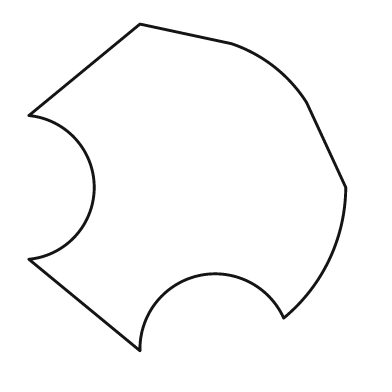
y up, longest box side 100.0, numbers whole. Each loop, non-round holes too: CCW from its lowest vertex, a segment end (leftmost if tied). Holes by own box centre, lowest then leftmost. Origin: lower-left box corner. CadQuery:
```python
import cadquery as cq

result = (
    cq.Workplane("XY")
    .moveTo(34.0, 0.0)
    .threePointArc((52.0, 23.0), (78.0, 10.0))
    .threePointArc((92.0, 28.0), (97.0, 50.0))
    .lineTo(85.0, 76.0)
    .threePointArc((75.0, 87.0), (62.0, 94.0))
    .lineTo(34.0, 100.0)
    .lineTo(0.0, 72.0)
    .threePointArc((20.0, 50.0), (0.0, 28.0))
    .close()
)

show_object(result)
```